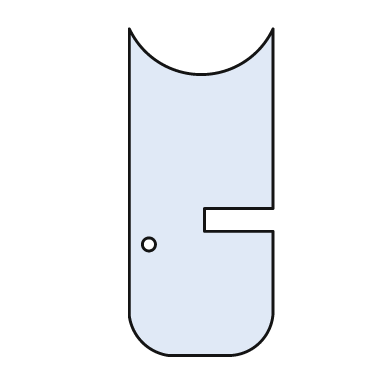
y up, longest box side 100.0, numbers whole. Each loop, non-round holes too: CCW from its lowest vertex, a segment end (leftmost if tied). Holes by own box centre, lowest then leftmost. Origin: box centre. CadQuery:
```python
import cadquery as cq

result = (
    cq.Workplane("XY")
    .moveTo(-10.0, -50.0)
    .lineTo(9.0, -50.0)
    .threePointArc((18.0, -46.0), (22.0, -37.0))
    .lineTo(22.0, -12.0)
    .lineTo(1.0, -12.0)
    .lineTo(1.0, -5.0)
    .lineTo(22.0, -5.0)
    .lineTo(22.0, 50.0)
    .threePointArc((0.0, 36.0), (-22.0, 50.0))
    .lineTo(-22.0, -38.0)
    .threePointArc((-18.0, -46.0), (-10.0, -50.0))
    .close()
    .moveTo(-16.0, -16.0)
    .circle(2.0)
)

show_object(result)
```